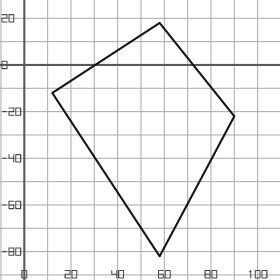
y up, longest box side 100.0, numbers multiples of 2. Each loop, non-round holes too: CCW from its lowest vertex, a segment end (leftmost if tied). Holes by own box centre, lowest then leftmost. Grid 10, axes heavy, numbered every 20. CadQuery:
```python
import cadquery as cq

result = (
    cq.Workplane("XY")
    .moveTo(58.0, -82.0)
    .lineTo(90.0, -22.0)
    .lineTo(58.0, 18.0)
    .lineTo(12.0, -12.0)
    .close()
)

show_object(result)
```